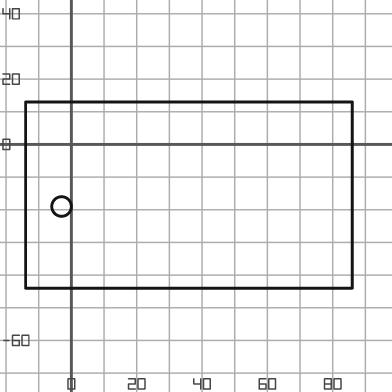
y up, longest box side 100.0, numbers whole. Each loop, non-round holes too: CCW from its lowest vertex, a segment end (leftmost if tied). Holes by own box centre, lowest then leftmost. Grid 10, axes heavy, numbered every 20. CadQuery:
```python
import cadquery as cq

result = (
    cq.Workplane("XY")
    .moveTo(-14.0, -44.0)
    .lineTo(86.0, -44.0)
    .lineTo(86.0, 13.0)
    .lineTo(-14.0, 13.0)
    .close()
    .moveTo(-3.0, -19.0)
    .circle(3.0)
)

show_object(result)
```